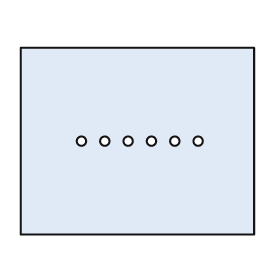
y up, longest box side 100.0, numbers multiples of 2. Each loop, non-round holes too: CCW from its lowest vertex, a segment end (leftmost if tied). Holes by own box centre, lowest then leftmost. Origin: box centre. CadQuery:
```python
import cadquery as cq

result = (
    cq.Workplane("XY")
    .moveTo(-50.0, -40.0)
    .lineTo(50.0, -40.0)
    .lineTo(50.0, 40.0)
    .lineTo(-50.0, 40.0)
    .close()
    .moveTo(-24.0, 0.0)
    .circle(2.0)
    .moveTo(-14.0, 0.0)
    .circle(2.0)
    .moveTo(-4.0, 0.0)
    .circle(2.0)
    .moveTo(6.0, 0.0)
    .circle(2.0)
    .moveTo(16.0, 0.0)
    .circle(2.0)
    .moveTo(26.0, 0.0)
    .circle(2.0)
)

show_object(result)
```